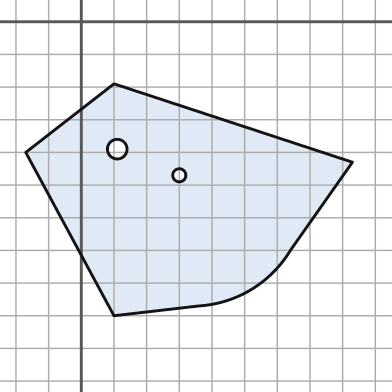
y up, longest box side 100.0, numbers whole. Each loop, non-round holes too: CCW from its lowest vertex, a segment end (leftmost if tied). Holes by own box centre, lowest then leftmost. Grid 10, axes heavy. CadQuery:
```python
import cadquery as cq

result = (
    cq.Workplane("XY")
    .moveTo(10.0, -90.0)
    .lineTo(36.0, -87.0)
    .threePointArc((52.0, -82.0), (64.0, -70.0))
    .lineTo(83.0, -43.0)
    .lineTo(10.0, -19.0)
    .lineTo(-17.0, -40.0)
    .close()
    .moveTo(30.0, -47.0)
    .circle(2.0)
    .moveTo(11.0, -39.0)
    .circle(3.0)
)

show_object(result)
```